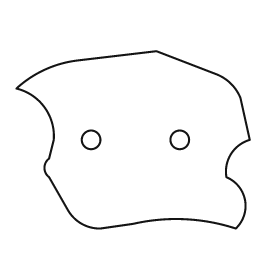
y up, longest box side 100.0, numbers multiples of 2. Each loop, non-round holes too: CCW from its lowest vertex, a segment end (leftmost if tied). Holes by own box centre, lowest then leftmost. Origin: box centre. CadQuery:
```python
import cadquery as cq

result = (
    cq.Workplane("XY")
    .moveTo(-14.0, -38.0)
    .lineTo(0.0, -36.0)
    .threePointArc((22.0, -34.0), (44.0, -38.0))
    .threePointArc((48.0, -26.0), (40.0, -16.0))
    .threePointArc((42.0, -6.0), (50.0, 0.0))
    .lineTo(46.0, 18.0)
    .threePointArc((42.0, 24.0), (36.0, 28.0))
    .lineTo(10.0, 38.0)
    .lineTo(-24.0, 34.0)
    .threePointArc((-38.0, 30.0), (-50.0, 22.0))
    .threePointArc((-38.0, 14.0), (-34.0, 0.0))
    .lineTo(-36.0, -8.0)
    .threePointArc((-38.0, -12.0), (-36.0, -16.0))
    .lineTo(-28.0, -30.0)
    .threePointArc((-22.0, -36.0), (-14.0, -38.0))
    .close()
    .moveTo(-18.0, 0.0)
    .circle(4.0)
    .moveTo(20.0, 0.0)
    .circle(4.0)
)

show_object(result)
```